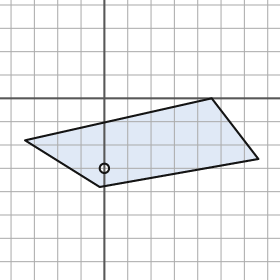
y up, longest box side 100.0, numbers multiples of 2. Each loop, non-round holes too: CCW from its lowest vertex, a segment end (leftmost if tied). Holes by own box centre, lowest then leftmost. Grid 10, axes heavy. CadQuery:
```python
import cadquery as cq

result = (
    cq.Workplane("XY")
    .moveTo(-2.0, -38.0)
    .lineTo(66.0, -26.0)
    .lineTo(46.0, 0.0)
    .lineTo(-34.0, -18.0)
    .close()
    .moveTo(0.0, -30.0)
    .circle(2.0)
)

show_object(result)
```